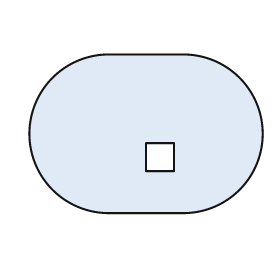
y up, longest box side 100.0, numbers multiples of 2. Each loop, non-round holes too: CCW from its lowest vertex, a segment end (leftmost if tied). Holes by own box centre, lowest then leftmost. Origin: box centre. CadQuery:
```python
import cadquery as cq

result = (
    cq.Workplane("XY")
    .moveTo(-16.0, -34.0)
    .lineTo(16.0, -34.0)
    .threePointArc((50.0, 0.0), (16.0, 34.0))
    .lineTo(-16.0, 34.0)
    .threePointArc((-50.0, 0.0), (-16.0, -34.0))
    .close()
    .moveTo(0.0, -16.0)
    .lineTo(12.0, -16.0)
    .lineTo(12.0, -4.0)
    .lineTo(0.0, -4.0)
    .close()
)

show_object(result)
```